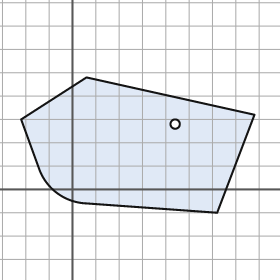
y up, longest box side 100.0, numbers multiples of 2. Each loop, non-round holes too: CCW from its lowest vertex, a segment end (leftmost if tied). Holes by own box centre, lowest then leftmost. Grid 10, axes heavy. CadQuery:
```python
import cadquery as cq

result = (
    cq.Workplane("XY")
    .moveTo(62.0, -10.0)
    .lineTo(78.0, 32.0)
    .lineTo(6.0, 48.0)
    .lineTo(-22.0, 30.0)
    .lineTo(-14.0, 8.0)
    .threePointArc((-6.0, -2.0), (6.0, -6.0))
    .close()
    .moveTo(44.0, 28.0)
    .circle(2.0)
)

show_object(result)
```